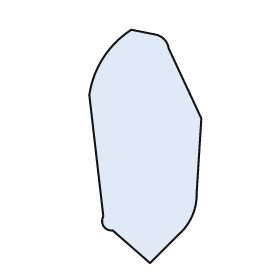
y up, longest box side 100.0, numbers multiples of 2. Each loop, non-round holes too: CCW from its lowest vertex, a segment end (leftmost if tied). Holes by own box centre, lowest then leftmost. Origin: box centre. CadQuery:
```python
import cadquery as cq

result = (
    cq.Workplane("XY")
    .moveTo(2.0, -50.0)
    .lineTo(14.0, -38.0)
    .threePointArc((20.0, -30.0), (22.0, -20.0))
    .lineTo(24.0, 12.0)
    .lineTo(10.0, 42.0)
    .threePointArc((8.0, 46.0), (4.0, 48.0))
    .lineTo(-6.0, 50.0)
    .threePointArc((-18.0, 38.0), (-24.0, 22.0))
    .lineTo(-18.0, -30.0)
    .threePointArc((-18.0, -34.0), (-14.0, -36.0))
    .close()
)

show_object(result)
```